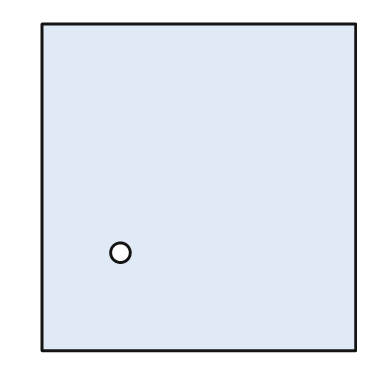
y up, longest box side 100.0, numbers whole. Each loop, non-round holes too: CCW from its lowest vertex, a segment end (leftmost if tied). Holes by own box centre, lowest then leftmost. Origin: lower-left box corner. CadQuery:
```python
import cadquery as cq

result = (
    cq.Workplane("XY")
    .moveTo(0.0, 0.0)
    .lineTo(96.0, 0.0)
    .lineTo(96.0, 100.0)
    .lineTo(0.0, 100.0)
    .close()
    .moveTo(24.0, 30.0)
    .circle(3.0)
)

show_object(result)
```